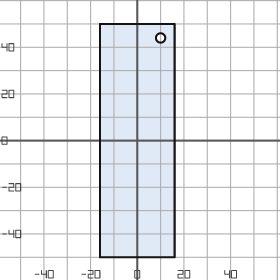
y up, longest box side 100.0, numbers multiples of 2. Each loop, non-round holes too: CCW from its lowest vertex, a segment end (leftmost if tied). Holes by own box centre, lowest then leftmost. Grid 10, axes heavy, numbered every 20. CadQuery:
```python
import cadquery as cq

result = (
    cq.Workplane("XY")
    .moveTo(-16.0, -50.0)
    .lineTo(16.0, -50.0)
    .lineTo(16.0, 50.0)
    .lineTo(-16.0, 50.0)
    .close()
    .moveTo(10.0, 44.0)
    .circle(2.0)
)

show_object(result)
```